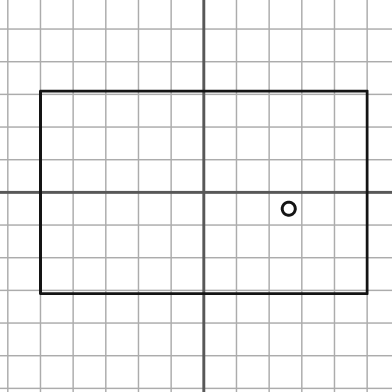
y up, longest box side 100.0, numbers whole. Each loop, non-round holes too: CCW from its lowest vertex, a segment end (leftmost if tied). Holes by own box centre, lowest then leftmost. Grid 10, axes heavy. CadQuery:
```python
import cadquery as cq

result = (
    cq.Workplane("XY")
    .moveTo(-50.0, -31.0)
    .lineTo(50.0, -31.0)
    .lineTo(50.0, 31.0)
    .lineTo(-50.0, 31.0)
    .close()
    .moveTo(26.0, -5.0)
    .circle(2.0)
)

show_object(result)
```